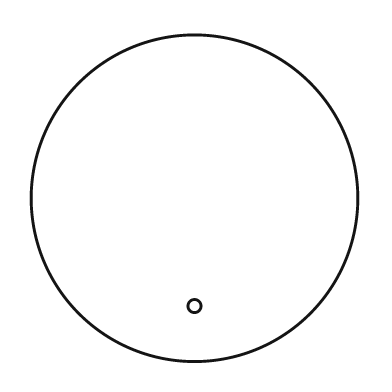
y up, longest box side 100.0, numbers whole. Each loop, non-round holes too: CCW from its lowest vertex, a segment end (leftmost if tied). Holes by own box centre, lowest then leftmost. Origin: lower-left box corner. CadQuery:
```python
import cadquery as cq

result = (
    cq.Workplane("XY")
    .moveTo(50.0, 50.0)
    .circle(50.0)
    .moveTo(50.0, 17.0)
    .circle(2.0)
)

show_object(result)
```